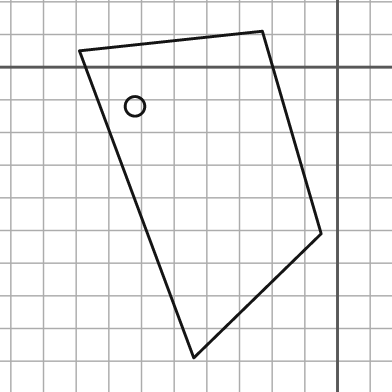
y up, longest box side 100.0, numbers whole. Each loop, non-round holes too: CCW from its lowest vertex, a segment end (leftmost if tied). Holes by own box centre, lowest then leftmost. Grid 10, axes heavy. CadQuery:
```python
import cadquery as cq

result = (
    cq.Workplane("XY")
    .moveTo(-44.0, -89.0)
    .lineTo(-5.0, -51.0)
    .lineTo(-23.0, 11.0)
    .lineTo(-79.0, 5.0)
    .close()
    .moveTo(-62.0, -12.0)
    .circle(3.0)
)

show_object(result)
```